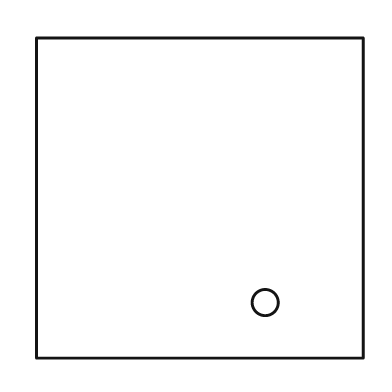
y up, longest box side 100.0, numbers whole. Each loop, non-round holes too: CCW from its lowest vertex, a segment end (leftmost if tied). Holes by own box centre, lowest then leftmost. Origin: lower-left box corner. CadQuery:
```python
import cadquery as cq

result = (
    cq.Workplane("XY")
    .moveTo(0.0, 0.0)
    .lineTo(100.0, 0.0)
    .lineTo(100.0, 98.0)
    .lineTo(0.0, 98.0)
    .close()
    .moveTo(70.0, 17.0)
    .circle(4.0)
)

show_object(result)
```